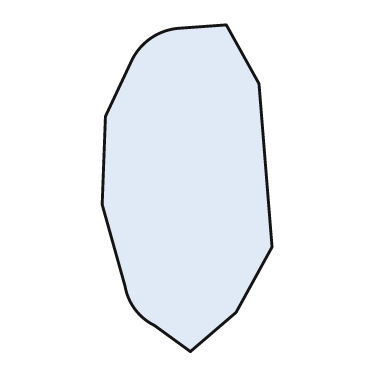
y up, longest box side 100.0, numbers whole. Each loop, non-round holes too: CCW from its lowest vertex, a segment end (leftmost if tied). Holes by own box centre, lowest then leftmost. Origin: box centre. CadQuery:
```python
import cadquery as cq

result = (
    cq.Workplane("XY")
    .moveTo(1.0, -50.0)
    .lineTo(15.0, -38.0)
    .lineTo(26.0, -18.0)
    .lineTo(22.0, 32.0)
    .lineTo(12.0, 50.0)
    .lineTo(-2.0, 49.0)
    .threePointArc((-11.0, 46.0), (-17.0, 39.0))
    .lineTo(-25.0, 22.0)
    .lineTo(-26.0, -5.0)
    .lineTo(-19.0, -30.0)
    .threePointArc((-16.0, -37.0), (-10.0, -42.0))
    .close()
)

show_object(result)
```